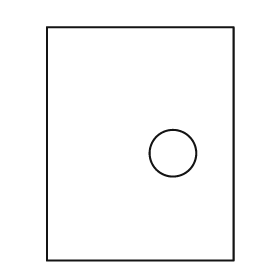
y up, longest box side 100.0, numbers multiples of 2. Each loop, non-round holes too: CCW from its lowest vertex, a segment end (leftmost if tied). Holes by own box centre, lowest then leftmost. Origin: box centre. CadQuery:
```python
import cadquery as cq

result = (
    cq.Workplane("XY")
    .moveTo(-40.0, -50.0)
    .lineTo(40.0, -50.0)
    .lineTo(40.0, 50.0)
    .lineTo(-40.0, 50.0)
    .close()
    .moveTo(14.0, -4.0)
    .circle(10.0)
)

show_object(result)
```